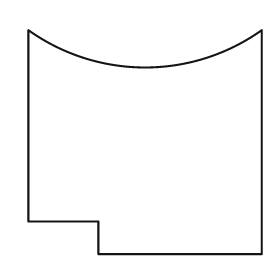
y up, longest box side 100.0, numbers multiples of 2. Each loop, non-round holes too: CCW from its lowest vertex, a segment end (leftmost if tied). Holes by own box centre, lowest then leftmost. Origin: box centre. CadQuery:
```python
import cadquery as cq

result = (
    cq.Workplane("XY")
    .moveTo(-20.0, -48.0)
    .lineTo(50.0, -48.0)
    .lineTo(50.0, 48.0)
    .threePointArc((0.0, 32.0), (-50.0, 48.0))
    .lineTo(-50.0, -34.0)
    .lineTo(-20.0, -34.0)
    .close()
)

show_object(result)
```